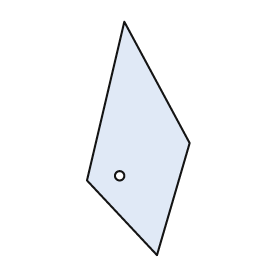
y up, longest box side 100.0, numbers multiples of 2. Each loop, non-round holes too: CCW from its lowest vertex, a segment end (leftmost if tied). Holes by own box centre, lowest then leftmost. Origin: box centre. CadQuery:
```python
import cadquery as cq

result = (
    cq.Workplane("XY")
    .moveTo(8.0, -50.0)
    .lineTo(22.0, -2.0)
    .lineTo(-6.0, 50.0)
    .lineTo(-22.0, -18.0)
    .close()
    .moveTo(-8.0, -16.0)
    .circle(2.0)
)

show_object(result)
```